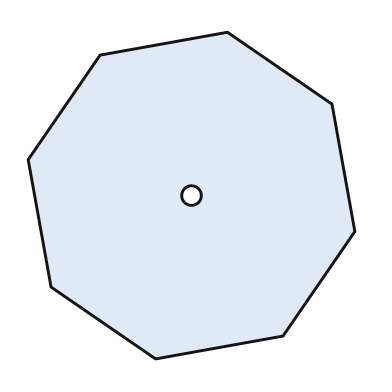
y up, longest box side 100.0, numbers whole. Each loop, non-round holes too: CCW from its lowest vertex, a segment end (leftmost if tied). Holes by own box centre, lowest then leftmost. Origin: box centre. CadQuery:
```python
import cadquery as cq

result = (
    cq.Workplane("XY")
    .moveTo(-11.0, -50.0)
    .lineTo(28.0, -43.0)
    .lineTo(50.0, -11.0)
    .lineTo(43.0, 28.0)
    .lineTo(11.0, 50.0)
    .lineTo(-28.0, 43.0)
    .lineTo(-50.0, 11.0)
    .lineTo(-43.0, -28.0)
    .close()
    .moveTo(0.0, 0.0)
    .circle(3.0)
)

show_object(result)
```